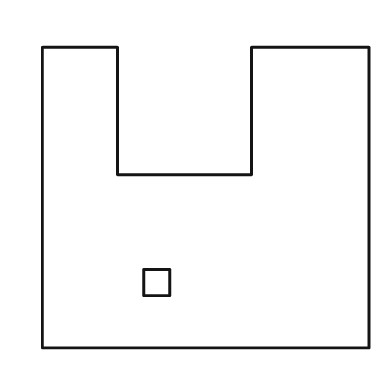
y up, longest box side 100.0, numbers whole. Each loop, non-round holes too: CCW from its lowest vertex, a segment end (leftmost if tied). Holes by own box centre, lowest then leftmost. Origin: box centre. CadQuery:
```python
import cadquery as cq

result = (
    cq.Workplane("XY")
    .moveTo(-50.0, -46.0)
    .lineTo(50.0, -46.0)
    .lineTo(50.0, 46.0)
    .lineTo(14.0, 46.0)
    .lineTo(14.0, 7.0)
    .lineTo(-27.0, 7.0)
    .lineTo(-27.0, 46.0)
    .lineTo(-50.0, 46.0)
    .close()
    .moveTo(-19.0, -30.0)
    .lineTo(-11.0, -30.0)
    .lineTo(-11.0, -22.0)
    .lineTo(-19.0, -22.0)
    .close()
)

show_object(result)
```